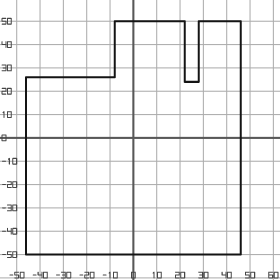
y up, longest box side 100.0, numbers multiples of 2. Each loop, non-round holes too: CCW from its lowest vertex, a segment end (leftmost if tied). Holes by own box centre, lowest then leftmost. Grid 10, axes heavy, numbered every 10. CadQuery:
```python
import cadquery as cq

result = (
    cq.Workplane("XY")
    .moveTo(-46.0, -50.0)
    .lineTo(46.0, -50.0)
    .lineTo(46.0, 50.0)
    .lineTo(28.0, 50.0)
    .lineTo(28.0, 24.0)
    .lineTo(22.0, 24.0)
    .lineTo(22.0, 50.0)
    .lineTo(-8.0, 50.0)
    .lineTo(-8.0, 26.0)
    .lineTo(-46.0, 26.0)
    .close()
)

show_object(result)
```